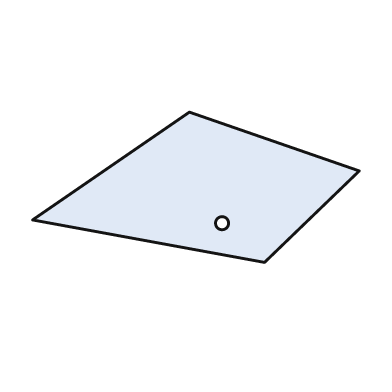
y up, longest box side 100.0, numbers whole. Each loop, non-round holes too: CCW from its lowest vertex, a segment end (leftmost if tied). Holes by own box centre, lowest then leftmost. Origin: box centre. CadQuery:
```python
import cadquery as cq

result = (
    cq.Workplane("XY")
    .moveTo(21.0, -23.0)
    .lineTo(50.0, 5.0)
    .lineTo(-2.0, 23.0)
    .lineTo(-50.0, -10.0)
    .close()
    .moveTo(8.0, -11.0)
    .circle(2.0)
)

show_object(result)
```